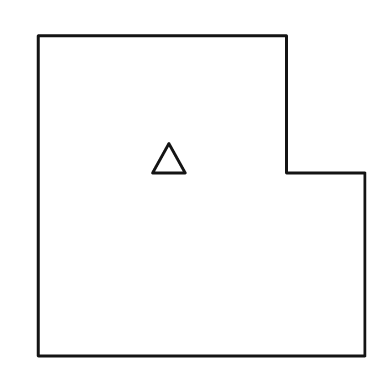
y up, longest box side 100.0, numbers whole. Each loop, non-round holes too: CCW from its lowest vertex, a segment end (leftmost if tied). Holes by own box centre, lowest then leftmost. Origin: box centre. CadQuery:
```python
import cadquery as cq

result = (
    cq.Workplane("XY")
    .moveTo(-50.0, -49.0)
    .lineTo(50.0, -49.0)
    .lineTo(50.0, 7.0)
    .lineTo(26.0, 7.0)
    .lineTo(26.0, 49.0)
    .lineTo(-50.0, 49.0)
    .close()
    .moveTo(-15.0, 7.0)
    .lineTo(-5.0, 7.0)
    .lineTo(-10.0, 16.0)
    .close()
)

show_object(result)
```